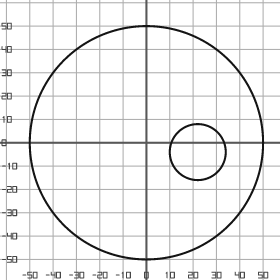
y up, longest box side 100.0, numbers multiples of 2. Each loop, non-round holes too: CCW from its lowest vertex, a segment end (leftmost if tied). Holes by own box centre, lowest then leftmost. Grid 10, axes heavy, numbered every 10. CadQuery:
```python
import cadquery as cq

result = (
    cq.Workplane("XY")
    .moveTo(0.0, 0.0)
    .circle(50.0)
    .moveTo(22.0, -4.0)
    .circle(12.0)
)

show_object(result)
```